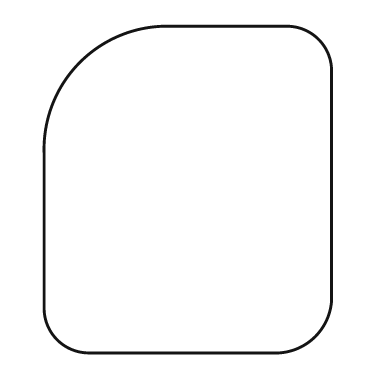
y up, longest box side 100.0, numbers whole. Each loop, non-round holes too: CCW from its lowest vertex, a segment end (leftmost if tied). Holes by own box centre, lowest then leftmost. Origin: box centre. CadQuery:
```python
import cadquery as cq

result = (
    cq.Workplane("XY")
    .moveTo(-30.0, -50.0)
    .lineTo(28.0, -50.0)
    .threePointArc((39.0, -45.0), (44.0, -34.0))
    .lineTo(44.0, 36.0)
    .threePointArc((40.0, 46.0), (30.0, 50.0))
    .lineTo(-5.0, 50.0)
    .threePointArc((-33.0, 39.0), (-44.0, 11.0))
    .lineTo(-44.0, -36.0)
    .threePointArc((-40.0, -46.0), (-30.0, -50.0))
    .close()
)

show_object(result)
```